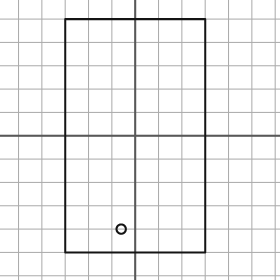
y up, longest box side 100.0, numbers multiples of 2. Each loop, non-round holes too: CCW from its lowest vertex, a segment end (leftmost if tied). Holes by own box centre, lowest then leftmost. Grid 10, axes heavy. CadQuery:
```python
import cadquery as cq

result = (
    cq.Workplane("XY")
    .moveTo(-30.0, -50.0)
    .lineTo(30.0, -50.0)
    .lineTo(30.0, 50.0)
    .lineTo(-30.0, 50.0)
    .close()
    .moveTo(-6.0, -40.0)
    .circle(2.0)
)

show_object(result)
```